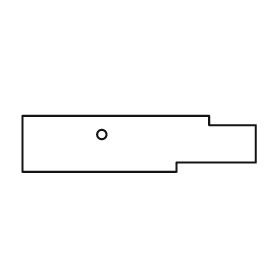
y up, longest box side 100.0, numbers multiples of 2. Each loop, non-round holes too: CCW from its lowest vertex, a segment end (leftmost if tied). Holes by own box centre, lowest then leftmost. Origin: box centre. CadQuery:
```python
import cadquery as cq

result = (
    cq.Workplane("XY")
    .moveTo(-50.0, -12.0)
    .lineTo(16.0, -12.0)
    .lineTo(16.0, -8.0)
    .lineTo(50.0, -8.0)
    .lineTo(50.0, 8.0)
    .lineTo(30.0, 8.0)
    .lineTo(30.0, 12.0)
    .lineTo(-50.0, 12.0)
    .close()
    .moveTo(-16.0, 4.0)
    .circle(2.0)
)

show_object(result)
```